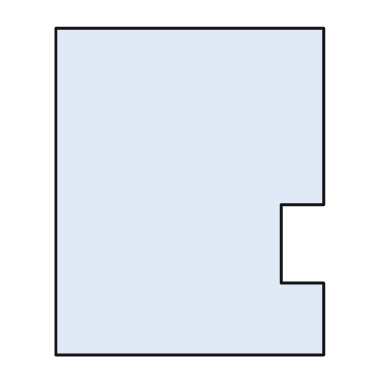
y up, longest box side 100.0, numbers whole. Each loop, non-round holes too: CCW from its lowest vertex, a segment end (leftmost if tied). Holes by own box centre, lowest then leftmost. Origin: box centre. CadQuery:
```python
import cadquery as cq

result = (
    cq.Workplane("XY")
    .moveTo(-41.0, -50.0)
    .lineTo(41.0, -50.0)
    .lineTo(41.0, -28.0)
    .lineTo(28.0, -28.0)
    .lineTo(28.0, -4.0)
    .lineTo(41.0, -4.0)
    .lineTo(41.0, 50.0)
    .lineTo(-41.0, 50.0)
    .close()
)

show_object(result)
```